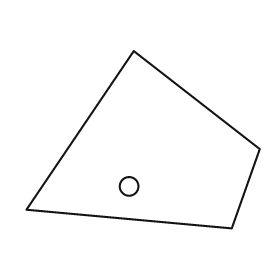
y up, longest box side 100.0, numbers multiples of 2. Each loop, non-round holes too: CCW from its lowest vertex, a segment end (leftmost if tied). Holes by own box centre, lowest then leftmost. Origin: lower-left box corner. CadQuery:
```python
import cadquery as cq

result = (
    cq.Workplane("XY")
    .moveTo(88.0, 0.0)
    .lineTo(100.0, 34.0)
    .lineTo(46.0, 76.0)
    .lineTo(0.0, 8.0)
    .close()
    .moveTo(44.0, 18.0)
    .circle(4.0)
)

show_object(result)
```